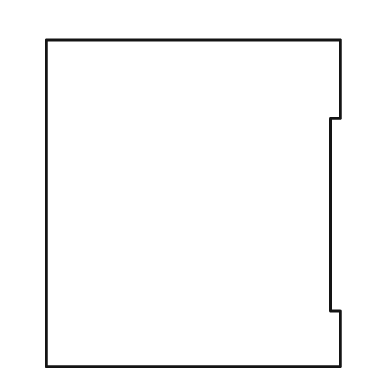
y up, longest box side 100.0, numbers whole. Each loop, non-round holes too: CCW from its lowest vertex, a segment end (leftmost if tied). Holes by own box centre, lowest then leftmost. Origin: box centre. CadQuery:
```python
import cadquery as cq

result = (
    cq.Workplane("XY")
    .moveTo(-45.0, -50.0)
    .lineTo(45.0, -50.0)
    .lineTo(45.0, -33.0)
    .lineTo(42.0, -33.0)
    .lineTo(42.0, 26.0)
    .lineTo(45.0, 26.0)
    .lineTo(45.0, 50.0)
    .lineTo(-45.0, 50.0)
    .close()
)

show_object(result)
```